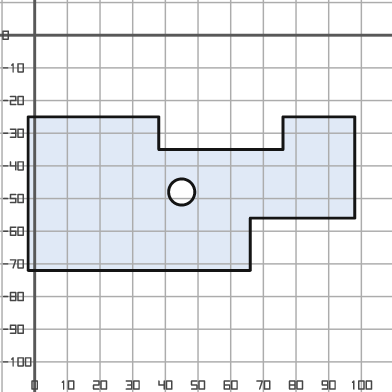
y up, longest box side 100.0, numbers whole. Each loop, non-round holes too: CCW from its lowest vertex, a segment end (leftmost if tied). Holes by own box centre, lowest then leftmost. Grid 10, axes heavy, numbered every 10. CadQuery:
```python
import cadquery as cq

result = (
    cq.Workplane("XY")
    .moveTo(-2.0, -72.0)
    .lineTo(66.0, -72.0)
    .lineTo(66.0, -56.0)
    .lineTo(98.0, -56.0)
    .lineTo(98.0, -25.0)
    .lineTo(76.0, -25.0)
    .lineTo(76.0, -35.0)
    .lineTo(38.0, -35.0)
    .lineTo(38.0, -25.0)
    .lineTo(-2.0, -25.0)
    .close()
    .moveTo(45.0, -48.0)
    .circle(4.0)
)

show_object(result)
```